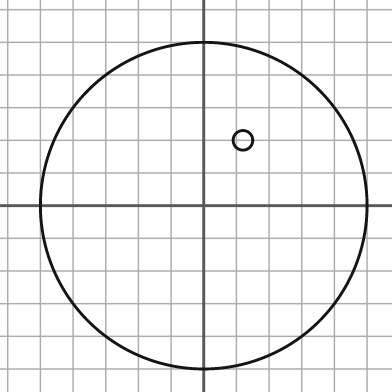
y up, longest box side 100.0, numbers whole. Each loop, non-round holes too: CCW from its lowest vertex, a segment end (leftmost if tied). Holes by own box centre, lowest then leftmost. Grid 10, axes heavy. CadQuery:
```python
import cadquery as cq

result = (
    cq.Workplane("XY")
    .moveTo(0.0, 0.0)
    .circle(50.0)
    .moveTo(12.0, 20.0)
    .circle(3.0)
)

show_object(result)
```